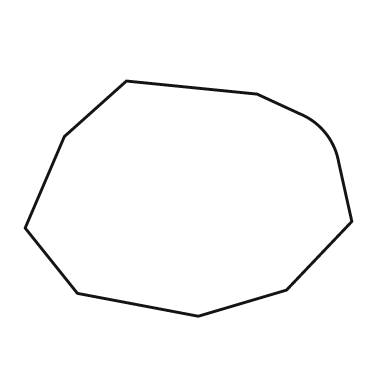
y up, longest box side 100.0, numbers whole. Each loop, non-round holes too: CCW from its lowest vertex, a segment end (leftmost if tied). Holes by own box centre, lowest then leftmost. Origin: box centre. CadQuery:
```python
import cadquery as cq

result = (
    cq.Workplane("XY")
    .moveTo(3.0, -36.0)
    .lineTo(30.0, -28.0)
    .lineTo(50.0, -7.0)
    .lineTo(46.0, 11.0)
    .threePointArc((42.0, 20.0), (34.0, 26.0))
    .lineTo(21.0, 32.0)
    .lineTo(-19.0, 36.0)
    .lineTo(-38.0, 19.0)
    .lineTo(-50.0, -9.0)
    .lineTo(-34.0, -29.0)
    .close()
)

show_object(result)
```